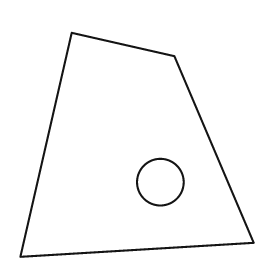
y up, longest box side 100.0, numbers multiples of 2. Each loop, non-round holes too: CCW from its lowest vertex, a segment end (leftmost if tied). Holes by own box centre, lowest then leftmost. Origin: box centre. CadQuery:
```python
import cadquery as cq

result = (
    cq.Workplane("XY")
    .moveTo(-50.0, -48.0)
    .lineTo(50.0, -42.0)
    .lineTo(16.0, 38.0)
    .lineTo(-28.0, 48.0)
    .close()
    .moveTo(10.0, -16.0)
    .circle(10.0)
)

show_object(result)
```